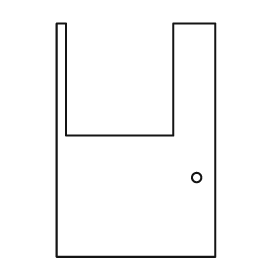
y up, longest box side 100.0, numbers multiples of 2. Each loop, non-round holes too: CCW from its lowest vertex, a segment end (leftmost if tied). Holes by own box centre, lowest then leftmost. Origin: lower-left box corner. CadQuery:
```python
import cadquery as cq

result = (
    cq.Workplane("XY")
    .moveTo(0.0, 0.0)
    .lineTo(68.0, 0.0)
    .lineTo(68.0, 100.0)
    .lineTo(50.0, 100.0)
    .lineTo(50.0, 52.0)
    .lineTo(4.0, 52.0)
    .lineTo(4.0, 100.0)
    .lineTo(0.0, 100.0)
    .close()
    .moveTo(60.0, 34.0)
    .circle(2.0)
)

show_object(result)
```